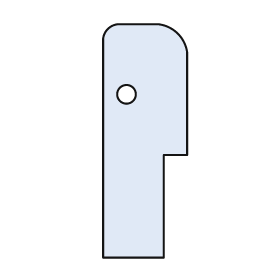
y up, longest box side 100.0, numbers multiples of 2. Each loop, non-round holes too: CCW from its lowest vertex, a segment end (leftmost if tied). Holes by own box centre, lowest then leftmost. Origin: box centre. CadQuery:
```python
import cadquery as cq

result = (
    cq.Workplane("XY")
    .moveTo(-18.0, -50.0)
    .lineTo(8.0, -50.0)
    .lineTo(8.0, -6.0)
    .lineTo(18.0, -6.0)
    .lineTo(18.0, 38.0)
    .threePointArc((14.0, 46.0), (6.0, 50.0))
    .lineTo(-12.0, 50.0)
    .threePointArc((-16.0, 48.0), (-18.0, 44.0))
    .close()
    .moveTo(-8.0, 20.0)
    .circle(4.0)
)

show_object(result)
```